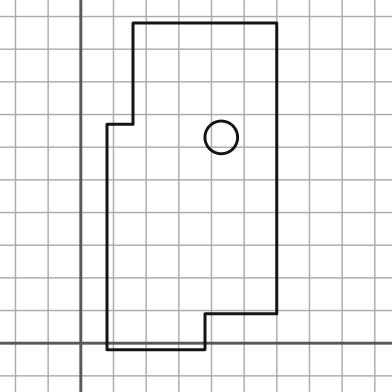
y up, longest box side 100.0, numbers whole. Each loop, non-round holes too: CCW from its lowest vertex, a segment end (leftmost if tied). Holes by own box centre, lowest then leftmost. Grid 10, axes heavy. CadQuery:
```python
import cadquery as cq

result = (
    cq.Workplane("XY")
    .moveTo(8.0, -2.0)
    .lineTo(38.0, -2.0)
    .lineTo(38.0, 9.0)
    .lineTo(60.0, 9.0)
    .lineTo(60.0, 98.0)
    .lineTo(16.0, 98.0)
    .lineTo(16.0, 67.0)
    .lineTo(8.0, 67.0)
    .close()
    .moveTo(43.0, 63.0)
    .circle(5.0)
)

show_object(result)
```